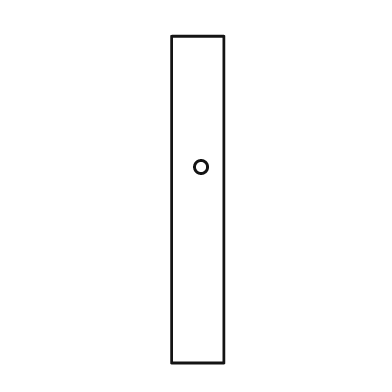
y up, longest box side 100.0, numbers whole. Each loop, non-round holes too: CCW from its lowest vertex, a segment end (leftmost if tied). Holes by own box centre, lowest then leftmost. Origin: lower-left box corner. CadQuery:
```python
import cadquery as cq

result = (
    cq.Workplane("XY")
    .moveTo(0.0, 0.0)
    .lineTo(16.0, 0.0)
    .lineTo(16.0, 100.0)
    .lineTo(0.0, 100.0)
    .close()
    .moveTo(9.0, 60.0)
    .circle(2.0)
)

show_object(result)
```